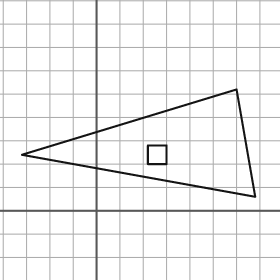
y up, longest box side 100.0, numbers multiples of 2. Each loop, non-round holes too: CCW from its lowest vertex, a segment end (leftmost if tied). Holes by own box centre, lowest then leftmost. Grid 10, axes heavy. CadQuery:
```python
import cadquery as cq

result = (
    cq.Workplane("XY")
    .moveTo(68.0, 6.0)
    .lineTo(60.0, 52.0)
    .lineTo(-32.0, 24.0)
    .close()
    .moveTo(22.0, 20.0)
    .lineTo(30.0, 20.0)
    .lineTo(30.0, 28.0)
    .lineTo(22.0, 28.0)
    .close()
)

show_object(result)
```